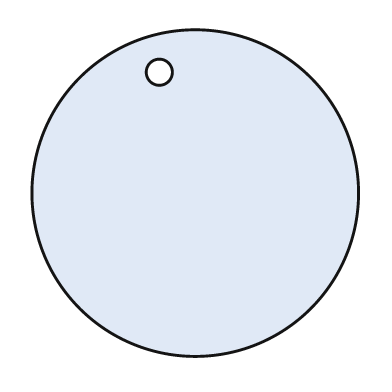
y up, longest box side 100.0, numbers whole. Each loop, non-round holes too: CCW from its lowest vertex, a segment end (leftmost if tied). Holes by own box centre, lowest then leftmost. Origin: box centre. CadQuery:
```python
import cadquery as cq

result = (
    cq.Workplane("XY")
    .moveTo(0.0, 0.0)
    .circle(50.0)
    .moveTo(-11.0, 37.0)
    .circle(4.0)
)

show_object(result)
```